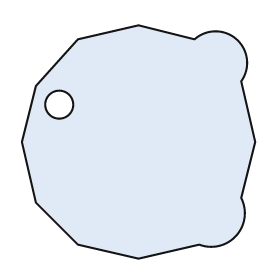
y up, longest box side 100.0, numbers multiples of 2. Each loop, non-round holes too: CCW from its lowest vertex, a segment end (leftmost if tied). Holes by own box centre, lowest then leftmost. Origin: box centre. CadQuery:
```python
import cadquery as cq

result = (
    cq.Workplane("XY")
    .moveTo(0.0, -50.0)
    .lineTo(26.0, -44.0)
    .threePointArc((42.0, -40.0), (44.0, -24.0))
    .lineTo(50.0, 0.0)
    .lineTo(44.0, 26.0)
    .threePointArc((42.0, 44.0), (24.0, 44.0))
    .lineTo(0.0, 50.0)
    .lineTo(-26.0, 44.0)
    .lineTo(-44.0, 24.0)
    .lineTo(-50.0, 0.0)
    .lineTo(-44.0, -26.0)
    .lineTo(-26.0, -44.0)
    .close()
    .moveTo(-34.0, 16.0)
    .circle(6.0)
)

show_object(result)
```